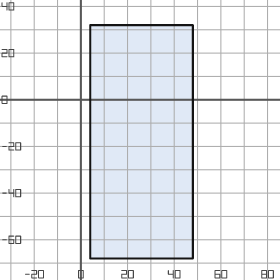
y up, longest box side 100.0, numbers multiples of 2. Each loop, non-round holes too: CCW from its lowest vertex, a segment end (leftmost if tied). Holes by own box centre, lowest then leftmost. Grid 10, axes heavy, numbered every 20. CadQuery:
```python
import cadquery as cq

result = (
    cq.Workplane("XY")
    .moveTo(4.0, -68.0)
    .lineTo(48.0, -68.0)
    .lineTo(48.0, 32.0)
    .lineTo(4.0, 32.0)
    .close()
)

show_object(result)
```